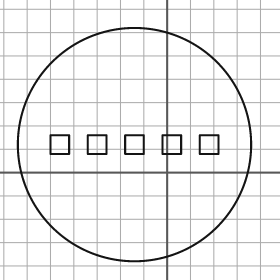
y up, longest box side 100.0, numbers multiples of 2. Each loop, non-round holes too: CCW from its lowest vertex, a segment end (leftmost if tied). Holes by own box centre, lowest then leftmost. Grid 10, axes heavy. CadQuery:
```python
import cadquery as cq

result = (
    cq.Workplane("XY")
    .moveTo(-14.0, 12.0)
    .circle(50.0)
    .moveTo(-50.0, 8.0)
    .lineTo(-42.0, 8.0)
    .lineTo(-42.0, 16.0)
    .lineTo(-50.0, 16.0)
    .close()
    .moveTo(-34.0, 8.0)
    .lineTo(-26.0, 8.0)
    .lineTo(-26.0, 16.0)
    .lineTo(-34.0, 16.0)
    .close()
    .moveTo(-18.0, 8.0)
    .lineTo(-10.0, 8.0)
    .lineTo(-10.0, 16.0)
    .lineTo(-18.0, 16.0)
    .close()
    .moveTo(-2.0, 8.0)
    .lineTo(6.0, 8.0)
    .lineTo(6.0, 16.0)
    .lineTo(-2.0, 16.0)
    .close()
    .moveTo(14.0, 8.0)
    .lineTo(22.0, 8.0)
    .lineTo(22.0, 16.0)
    .lineTo(14.0, 16.0)
    .close()
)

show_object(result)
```